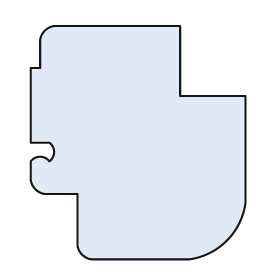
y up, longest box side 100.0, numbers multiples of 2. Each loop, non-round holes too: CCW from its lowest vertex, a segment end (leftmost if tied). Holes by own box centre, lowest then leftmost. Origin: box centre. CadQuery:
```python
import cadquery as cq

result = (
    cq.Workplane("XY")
    .moveTo(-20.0, -50.0)
    .lineTo(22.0, -50.0)
    .threePointArc((38.0, -42.0), (46.0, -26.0))
    .lineTo(46.0, 20.0)
    .lineTo(18.0, 20.0)
    .lineTo(18.0, 50.0)
    .lineTo(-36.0, 50.0)
    .threePointArc((-40.0, 48.0), (-42.0, 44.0))
    .lineTo(-42.0, 32.0)
    .lineTo(-46.0, 32.0)
    .lineTo(-46.0, 0.0)
    .lineTo(-38.0, 0.0)
    .threePointArc((-36.0, -4.0), (-38.0, -8.0))
    .threePointArc((-42.0, -6.0), (-46.0, -8.0))
    .lineTo(-46.0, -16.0)
    .threePointArc((-44.0, -20.0), (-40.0, -22.0))
    .lineTo(-26.0, -22.0)
    .lineTo(-26.0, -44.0)
    .threePointArc((-24.0, -48.0), (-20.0, -50.0))
    .close()
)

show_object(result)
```